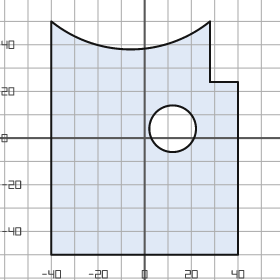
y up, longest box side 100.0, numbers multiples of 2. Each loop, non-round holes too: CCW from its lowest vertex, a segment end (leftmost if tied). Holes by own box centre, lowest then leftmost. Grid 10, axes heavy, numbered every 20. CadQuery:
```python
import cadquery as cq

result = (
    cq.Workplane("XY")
    .moveTo(-40.0, -50.0)
    .lineTo(40.0, -50.0)
    .lineTo(40.0, 24.0)
    .lineTo(28.0, 24.0)
    .lineTo(28.0, 50.0)
    .threePointArc((-6.0, 38.0), (-40.0, 50.0))
    .close()
    .moveTo(12.0, 4.0)
    .circle(10.0)
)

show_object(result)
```